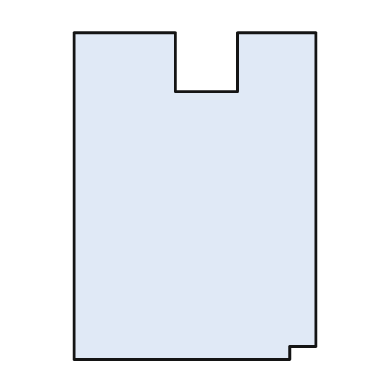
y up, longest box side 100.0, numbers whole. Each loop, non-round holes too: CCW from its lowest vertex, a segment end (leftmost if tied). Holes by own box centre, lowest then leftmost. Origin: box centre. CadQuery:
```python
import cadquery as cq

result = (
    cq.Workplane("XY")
    .moveTo(-37.0, -50.0)
    .lineTo(29.0, -50.0)
    .lineTo(29.0, -46.0)
    .lineTo(37.0, -46.0)
    .lineTo(37.0, 50.0)
    .lineTo(13.0, 50.0)
    .lineTo(13.0, 32.0)
    .lineTo(-6.0, 32.0)
    .lineTo(-6.0, 50.0)
    .lineTo(-37.0, 50.0)
    .close()
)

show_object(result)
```